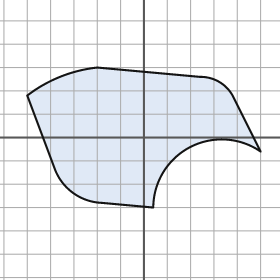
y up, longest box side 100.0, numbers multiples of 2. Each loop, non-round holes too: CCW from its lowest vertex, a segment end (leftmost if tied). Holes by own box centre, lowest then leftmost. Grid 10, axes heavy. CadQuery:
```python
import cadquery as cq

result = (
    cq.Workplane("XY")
    .moveTo(4.0, -30.0)
    .threePointArc((20.0, -4.0), (50.0, -6.0))
    .lineTo(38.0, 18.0)
    .threePointArc((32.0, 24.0), (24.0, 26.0))
    .lineTo(-20.0, 30.0)
    .threePointArc((-36.0, 26.0), (-50.0, 18.0))
    .lineTo(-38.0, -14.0)
    .threePointArc((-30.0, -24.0), (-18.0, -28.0))
    .close()
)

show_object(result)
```